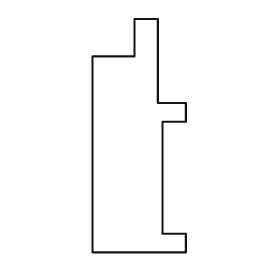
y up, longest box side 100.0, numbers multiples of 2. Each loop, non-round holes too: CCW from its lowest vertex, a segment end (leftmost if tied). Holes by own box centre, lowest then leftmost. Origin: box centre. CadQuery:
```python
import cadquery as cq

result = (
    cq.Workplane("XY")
    .moveTo(-20.0, -50.0)
    .lineTo(20.0, -50.0)
    .lineTo(20.0, -42.0)
    .lineTo(10.0, -42.0)
    .lineTo(10.0, 6.0)
    .lineTo(20.0, 6.0)
    .lineTo(20.0, 14.0)
    .lineTo(8.0, 14.0)
    .lineTo(8.0, 50.0)
    .lineTo(-2.0, 50.0)
    .lineTo(-2.0, 34.0)
    .lineTo(-20.0, 34.0)
    .close()
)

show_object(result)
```